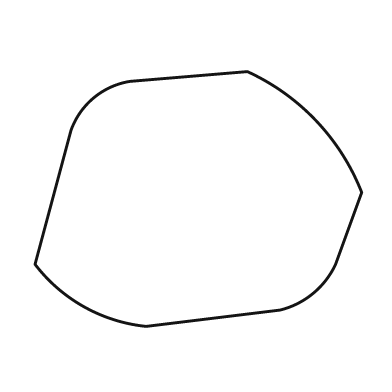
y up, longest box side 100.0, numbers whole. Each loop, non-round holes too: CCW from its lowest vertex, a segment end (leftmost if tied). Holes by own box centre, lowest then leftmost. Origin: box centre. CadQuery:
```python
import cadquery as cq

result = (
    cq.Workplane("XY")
    .moveTo(-16.0, -39.0)
    .lineTo(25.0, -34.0)
    .threePointArc((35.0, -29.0), (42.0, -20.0))
    .lineTo(50.0, 2.0)
    .threePointArc((36.0, 24.0), (15.0, 39.0))
    .lineTo(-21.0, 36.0)
    .threePointArc((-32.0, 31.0), (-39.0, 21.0))
    .lineTo(-50.0, -20.0)
    .threePointArc((-35.0, -33.0), (-16.0, -39.0))
    .close()
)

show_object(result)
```